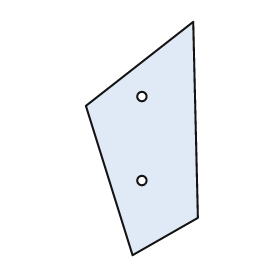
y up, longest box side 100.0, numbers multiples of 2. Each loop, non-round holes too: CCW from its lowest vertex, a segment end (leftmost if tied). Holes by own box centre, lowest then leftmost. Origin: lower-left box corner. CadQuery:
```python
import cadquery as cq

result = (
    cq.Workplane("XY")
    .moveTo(20.0, 0.0)
    .lineTo(48.0, 16.0)
    .lineTo(46.0, 100.0)
    .lineTo(0.0, 64.0)
    .close()
    .moveTo(24.0, 32.0)
    .circle(2.0)
    .moveTo(24.0, 68.0)
    .circle(2.0)
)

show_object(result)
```